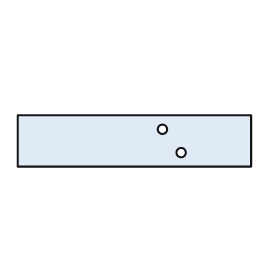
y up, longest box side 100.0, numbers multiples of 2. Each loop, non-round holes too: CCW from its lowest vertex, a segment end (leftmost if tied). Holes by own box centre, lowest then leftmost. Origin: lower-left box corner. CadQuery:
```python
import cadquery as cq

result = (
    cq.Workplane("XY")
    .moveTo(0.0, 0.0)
    .lineTo(100.0, 0.0)
    .lineTo(100.0, 22.0)
    .lineTo(0.0, 22.0)
    .close()
    .moveTo(70.0, 6.0)
    .circle(2.0)
    .moveTo(62.0, 16.0)
    .circle(2.0)
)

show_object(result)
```